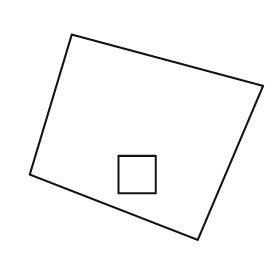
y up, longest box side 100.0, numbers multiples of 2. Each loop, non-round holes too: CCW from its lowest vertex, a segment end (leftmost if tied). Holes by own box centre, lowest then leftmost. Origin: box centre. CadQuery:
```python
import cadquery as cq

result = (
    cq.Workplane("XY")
    .moveTo(22.0, -44.0)
    .lineTo(50.0, 22.0)
    .lineTo(-32.0, 44.0)
    .lineTo(-50.0, -16.0)
    .close()
    .moveTo(-12.0, -24.0)
    .lineTo(4.0, -24.0)
    .lineTo(4.0, -8.0)
    .lineTo(-12.0, -8.0)
    .close()
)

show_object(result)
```